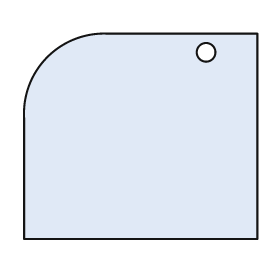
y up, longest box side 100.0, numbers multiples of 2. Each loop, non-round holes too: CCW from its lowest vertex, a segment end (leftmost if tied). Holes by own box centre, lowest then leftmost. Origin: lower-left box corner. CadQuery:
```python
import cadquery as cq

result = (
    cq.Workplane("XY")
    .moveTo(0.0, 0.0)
    .lineTo(100.0, 0.0)
    .lineTo(100.0, 88.0)
    .lineTo(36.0, 88.0)
    .threePointArc((10.0, 78.0), (0.0, 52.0))
    .close()
    .moveTo(78.0, 80.0)
    .circle(4.0)
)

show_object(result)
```